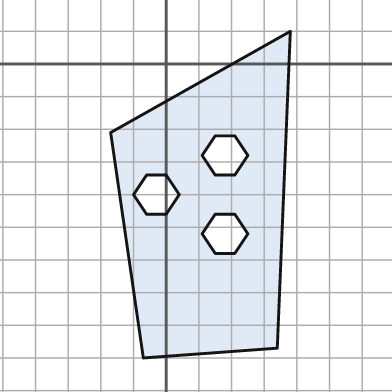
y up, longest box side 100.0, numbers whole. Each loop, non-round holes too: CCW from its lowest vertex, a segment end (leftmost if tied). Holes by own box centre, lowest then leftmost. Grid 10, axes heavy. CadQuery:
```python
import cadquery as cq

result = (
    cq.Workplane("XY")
    .moveTo(-7.0, -90.0)
    .lineTo(34.0, -87.0)
    .lineTo(38.0, 10.0)
    .lineTo(-17.0, -21.0)
    .close()
    .moveTo(15.0, -58.0)
    .lineTo(21.0, -58.0)
    .lineTo(25.0, -52.0)
    .lineTo(21.0, -46.0)
    .lineTo(15.0, -46.0)
    .lineTo(11.0, -52.0)
    .close()
    .moveTo(-6.0, -46.0)
    .lineTo(0.0, -46.0)
    .lineTo(4.0, -40.0)
    .lineTo(0.0, -34.0)
    .lineTo(-6.0, -34.0)
    .lineTo(-10.0, -40.0)
    .close()
    .moveTo(15.0, -34.0)
    .lineTo(21.0, -34.0)
    .lineTo(25.0, -28.0)
    .lineTo(21.0, -22.0)
    .lineTo(15.0, -22.0)
    .lineTo(11.0, -28.0)
    .close()
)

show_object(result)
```